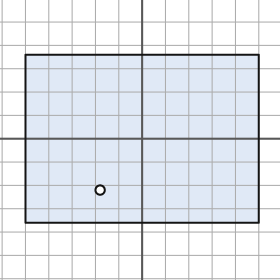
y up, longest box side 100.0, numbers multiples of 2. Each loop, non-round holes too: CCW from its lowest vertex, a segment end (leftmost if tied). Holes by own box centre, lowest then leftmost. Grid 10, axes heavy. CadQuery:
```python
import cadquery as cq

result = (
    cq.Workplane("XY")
    .moveTo(-50.0, -36.0)
    .lineTo(50.0, -36.0)
    .lineTo(50.0, 36.0)
    .lineTo(-50.0, 36.0)
    .close()
    .moveTo(-18.0, -22.0)
    .circle(2.0)
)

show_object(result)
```